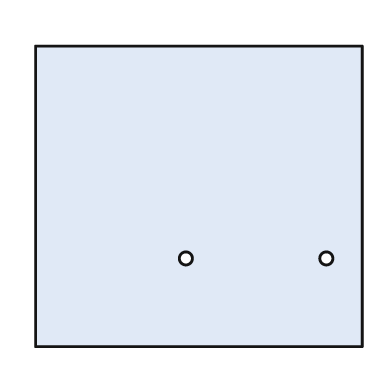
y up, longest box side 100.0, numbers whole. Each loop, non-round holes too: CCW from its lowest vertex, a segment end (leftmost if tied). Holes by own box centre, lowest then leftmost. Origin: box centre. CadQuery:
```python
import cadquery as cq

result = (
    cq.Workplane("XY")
    .moveTo(-50.0, -46.0)
    .lineTo(50.0, -46.0)
    .lineTo(50.0, 46.0)
    .lineTo(-50.0, 46.0)
    .close()
    .moveTo(-4.0, -19.0)
    .circle(2.0)
    .moveTo(39.0, -19.0)
    .circle(2.0)
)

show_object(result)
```